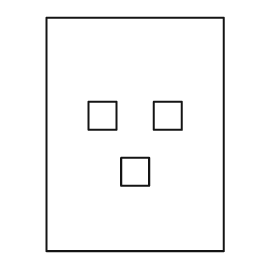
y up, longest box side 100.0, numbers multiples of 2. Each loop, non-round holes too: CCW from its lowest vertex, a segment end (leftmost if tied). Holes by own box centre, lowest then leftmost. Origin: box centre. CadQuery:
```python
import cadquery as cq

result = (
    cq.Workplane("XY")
    .moveTo(-38.0, -50.0)
    .lineTo(38.0, -50.0)
    .lineTo(38.0, 50.0)
    .lineTo(-38.0, 50.0)
    .close()
    .moveTo(-6.0, -22.0)
    .lineTo(6.0, -22.0)
    .lineTo(6.0, -10.0)
    .lineTo(-6.0, -10.0)
    .close()
    .moveTo(-20.0, 2.0)
    .lineTo(-8.0, 2.0)
    .lineTo(-8.0, 14.0)
    .lineTo(-20.0, 14.0)
    .close()
    .moveTo(8.0, 2.0)
    .lineTo(20.0, 2.0)
    .lineTo(20.0, 14.0)
    .lineTo(8.0, 14.0)
    .close()
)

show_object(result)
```